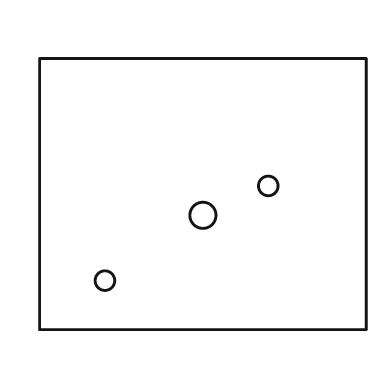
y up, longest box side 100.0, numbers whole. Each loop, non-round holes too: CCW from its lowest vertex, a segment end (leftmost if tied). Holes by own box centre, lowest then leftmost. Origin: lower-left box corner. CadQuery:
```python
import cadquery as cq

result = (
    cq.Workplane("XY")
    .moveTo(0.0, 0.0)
    .lineTo(100.0, 0.0)
    .lineTo(100.0, 83.0)
    .lineTo(0.0, 83.0)
    .close()
    .moveTo(20.0, 15.0)
    .circle(3.0)
    .moveTo(50.0, 35.0)
    .circle(4.0)
    .moveTo(70.0, 44.0)
    .circle(3.0)
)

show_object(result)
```